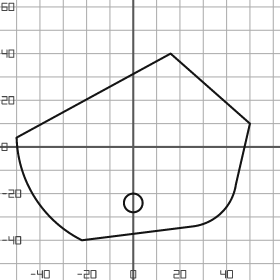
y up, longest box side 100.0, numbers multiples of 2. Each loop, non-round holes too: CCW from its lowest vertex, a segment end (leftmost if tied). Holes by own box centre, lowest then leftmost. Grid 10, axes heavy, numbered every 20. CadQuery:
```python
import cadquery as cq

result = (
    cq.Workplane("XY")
    .moveTo(-22.0, -40.0)
    .lineTo(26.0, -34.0)
    .threePointArc((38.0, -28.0), (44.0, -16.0))
    .lineTo(50.0, 10.0)
    .lineTo(16.0, 40.0)
    .lineTo(-50.0, 4.0)
    .threePointArc((-42.0, -22.0), (-22.0, -40.0))
    .close()
    .moveTo(0.0, -24.0)
    .circle(4.0)
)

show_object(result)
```